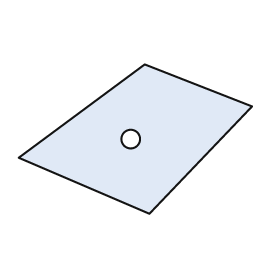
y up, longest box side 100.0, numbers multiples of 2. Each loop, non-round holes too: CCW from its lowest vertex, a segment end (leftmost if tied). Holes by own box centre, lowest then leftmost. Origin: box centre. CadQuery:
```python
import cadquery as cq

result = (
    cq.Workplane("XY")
    .moveTo(6.0, -32.0)
    .lineTo(50.0, 14.0)
    .lineTo(4.0, 32.0)
    .lineTo(-50.0, -8.0)
    .close()
    .moveTo(-2.0, 0.0)
    .circle(4.0)
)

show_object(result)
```